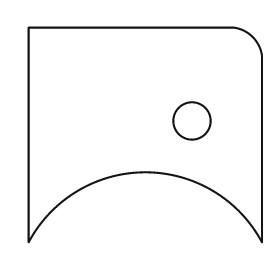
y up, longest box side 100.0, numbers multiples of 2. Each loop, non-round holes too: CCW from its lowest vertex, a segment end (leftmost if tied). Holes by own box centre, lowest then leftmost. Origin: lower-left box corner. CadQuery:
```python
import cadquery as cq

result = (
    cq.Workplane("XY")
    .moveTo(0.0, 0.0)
    .threePointArc((50.0, 30.0), (100.0, 0.0))
    .lineTo(100.0, 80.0)
    .threePointArc((96.0, 88.0), (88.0, 92.0))
    .lineTo(0.0, 92.0)
    .close()
    .moveTo(70.0, 52.0)
    .circle(8.0)
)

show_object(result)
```